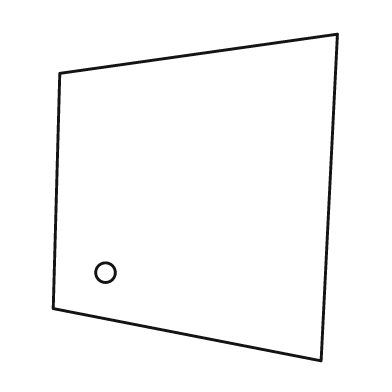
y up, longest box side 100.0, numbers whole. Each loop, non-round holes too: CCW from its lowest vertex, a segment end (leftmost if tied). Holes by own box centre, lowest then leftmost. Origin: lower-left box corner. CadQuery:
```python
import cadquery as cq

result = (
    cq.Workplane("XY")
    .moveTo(82.0, 0.0)
    .lineTo(87.0, 100.0)
    .lineTo(2.0, 88.0)
    .lineTo(0.0, 16.0)
    .close()
    .moveTo(16.0, 27.0)
    .circle(3.0)
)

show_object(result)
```